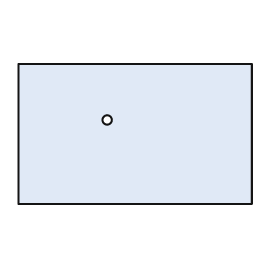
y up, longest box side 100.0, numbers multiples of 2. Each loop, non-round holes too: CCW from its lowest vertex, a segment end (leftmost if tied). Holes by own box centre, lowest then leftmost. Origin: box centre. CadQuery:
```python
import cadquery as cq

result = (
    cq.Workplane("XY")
    .moveTo(-50.0, -30.0)
    .lineTo(50.0, -30.0)
    .lineTo(50.0, 30.0)
    .lineTo(-50.0, 30.0)
    .close()
    .moveTo(-12.0, 6.0)
    .circle(2.0)
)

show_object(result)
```